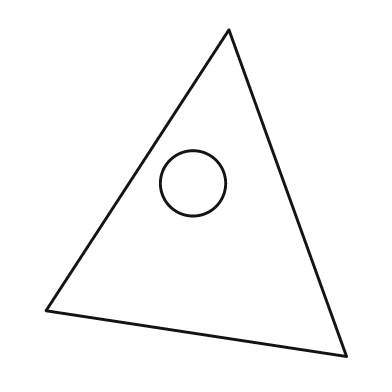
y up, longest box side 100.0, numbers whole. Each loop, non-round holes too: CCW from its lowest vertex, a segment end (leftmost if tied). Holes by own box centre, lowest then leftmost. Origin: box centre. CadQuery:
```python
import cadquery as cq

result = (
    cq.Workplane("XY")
    .moveTo(46.0, -50.0)
    .lineTo(10.0, 50.0)
    .lineTo(-46.0, -36.0)
    .close()
    .moveTo(-1.0, 3.0)
    .circle(10.0)
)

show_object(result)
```